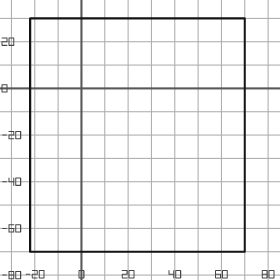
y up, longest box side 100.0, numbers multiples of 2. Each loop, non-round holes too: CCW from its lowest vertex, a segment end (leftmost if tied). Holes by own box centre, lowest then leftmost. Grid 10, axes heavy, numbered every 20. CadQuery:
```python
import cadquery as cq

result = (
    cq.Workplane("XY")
    .moveTo(-22.0, -70.0)
    .lineTo(70.0, -70.0)
    .lineTo(70.0, 30.0)
    .lineTo(-22.0, 30.0)
    .close()
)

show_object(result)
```